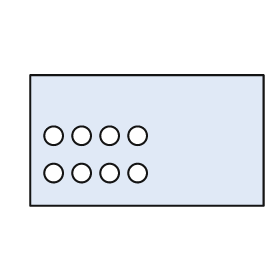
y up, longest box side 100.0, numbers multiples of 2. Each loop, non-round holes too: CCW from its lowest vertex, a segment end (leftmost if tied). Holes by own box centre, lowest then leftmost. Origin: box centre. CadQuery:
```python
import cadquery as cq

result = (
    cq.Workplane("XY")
    .moveTo(-50.0, -28.0)
    .lineTo(50.0, -28.0)
    .lineTo(50.0, 28.0)
    .lineTo(-50.0, 28.0)
    .close()
    .moveTo(-40.0, -14.0)
    .circle(4.0)
    .moveTo(-28.0, -14.0)
    .circle(4.0)
    .moveTo(-16.0, -14.0)
    .circle(4.0)
    .moveTo(-4.0, -14.0)
    .circle(4.0)
    .moveTo(-40.0, 2.0)
    .circle(4.0)
    .moveTo(-28.0, 2.0)
    .circle(4.0)
    .moveTo(-16.0, 2.0)
    .circle(4.0)
    .moveTo(-4.0, 2.0)
    .circle(4.0)
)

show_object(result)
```